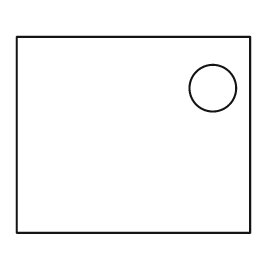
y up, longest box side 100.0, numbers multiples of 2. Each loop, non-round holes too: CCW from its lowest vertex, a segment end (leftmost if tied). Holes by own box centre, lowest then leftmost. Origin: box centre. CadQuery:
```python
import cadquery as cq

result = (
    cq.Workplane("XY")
    .moveTo(-50.0, -42.0)
    .lineTo(50.0, -42.0)
    .lineTo(50.0, 42.0)
    .lineTo(-50.0, 42.0)
    .close()
    .moveTo(34.0, 20.0)
    .circle(10.0)
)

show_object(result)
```